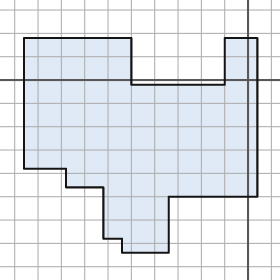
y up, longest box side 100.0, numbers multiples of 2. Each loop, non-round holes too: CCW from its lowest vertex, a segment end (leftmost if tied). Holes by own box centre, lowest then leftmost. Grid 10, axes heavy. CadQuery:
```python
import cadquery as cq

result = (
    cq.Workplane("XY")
    .moveTo(-54.0, -74.0)
    .lineTo(-34.0, -74.0)
    .lineTo(-34.0, -50.0)
    .lineTo(4.0, -50.0)
    .lineTo(4.0, 18.0)
    .lineTo(-10.0, 18.0)
    .lineTo(-10.0, -2.0)
    .lineTo(-50.0, -2.0)
    .lineTo(-50.0, 18.0)
    .lineTo(-96.0, 18.0)
    .lineTo(-96.0, -38.0)
    .lineTo(-78.0, -38.0)
    .lineTo(-78.0, -46.0)
    .lineTo(-62.0, -46.0)
    .lineTo(-62.0, -68.0)
    .lineTo(-54.0, -68.0)
    .close()
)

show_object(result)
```